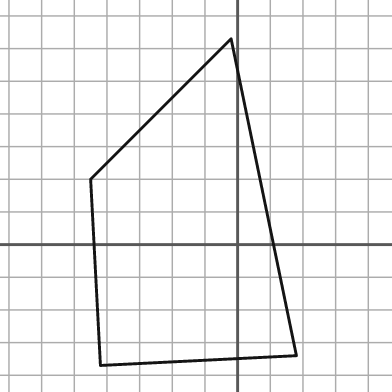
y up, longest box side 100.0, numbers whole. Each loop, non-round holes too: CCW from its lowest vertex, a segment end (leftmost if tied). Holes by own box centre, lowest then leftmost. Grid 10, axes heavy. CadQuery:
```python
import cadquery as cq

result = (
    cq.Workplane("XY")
    .moveTo(-42.0, -37.0)
    .lineTo(18.0, -34.0)
    .lineTo(-2.0, 63.0)
    .lineTo(-45.0, 20.0)
    .close()
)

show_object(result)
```